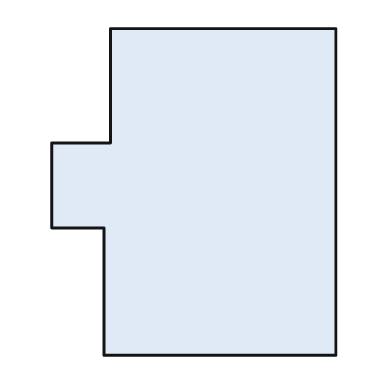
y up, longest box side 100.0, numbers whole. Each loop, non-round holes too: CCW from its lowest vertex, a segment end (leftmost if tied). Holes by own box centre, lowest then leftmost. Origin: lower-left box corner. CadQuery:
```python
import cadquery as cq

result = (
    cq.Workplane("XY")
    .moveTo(16.0, 0.0)
    .lineTo(87.0, 0.0)
    .lineTo(87.0, 100.0)
    .lineTo(18.0, 100.0)
    .lineTo(18.0, 65.0)
    .lineTo(0.0, 65.0)
    .lineTo(0.0, 39.0)
    .lineTo(16.0, 39.0)
    .close()
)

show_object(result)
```